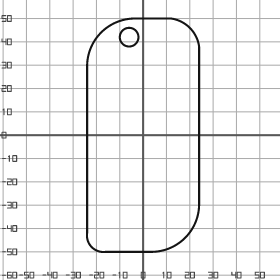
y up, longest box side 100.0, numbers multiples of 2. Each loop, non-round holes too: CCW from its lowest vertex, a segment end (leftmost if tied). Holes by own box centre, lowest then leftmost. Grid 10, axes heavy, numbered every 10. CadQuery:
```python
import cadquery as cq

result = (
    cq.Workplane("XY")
    .moveTo(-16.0, -50.0)
    .lineTo(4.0, -50.0)
    .threePointArc((18.0, -44.0), (24.0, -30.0))
    .lineTo(24.0, 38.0)
    .threePointArc((20.0, 46.0), (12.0, 50.0))
    .lineTo(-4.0, 50.0)
    .threePointArc((-18.0, 44.0), (-24.0, 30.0))
    .lineTo(-24.0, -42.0)
    .threePointArc((-22.0, -48.0), (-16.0, -50.0))
    .close()
    .moveTo(-6.0, 42.0)
    .circle(4.0)
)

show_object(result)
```